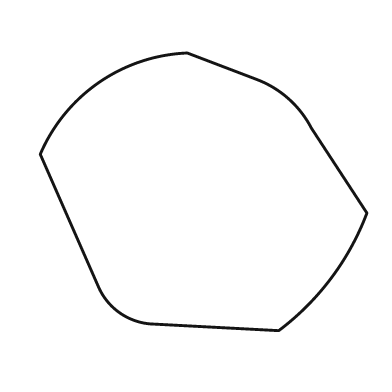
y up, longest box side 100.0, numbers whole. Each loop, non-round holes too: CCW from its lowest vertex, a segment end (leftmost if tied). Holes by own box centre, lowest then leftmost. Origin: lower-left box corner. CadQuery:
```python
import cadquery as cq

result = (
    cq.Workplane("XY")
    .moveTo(73.0, 0.0)
    .threePointArc((89.0, 16.0), (100.0, 36.0))
    .lineTo(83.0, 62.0)
    .threePointArc((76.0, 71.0), (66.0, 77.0))
    .lineTo(45.0, 85.0)
    .threePointArc((18.0, 76.0), (0.0, 54.0))
    .lineTo(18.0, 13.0)
    .threePointArc((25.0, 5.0), (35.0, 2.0))
    .close()
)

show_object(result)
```